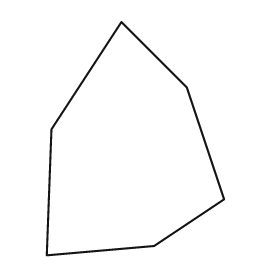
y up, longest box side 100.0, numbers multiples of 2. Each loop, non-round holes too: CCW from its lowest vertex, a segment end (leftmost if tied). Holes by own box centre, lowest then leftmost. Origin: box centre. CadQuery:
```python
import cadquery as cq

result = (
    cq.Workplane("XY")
    .moveTo(-38.0, -50.0)
    .lineTo(8.0, -46.0)
    .lineTo(38.0, -26.0)
    .lineTo(22.0, 22.0)
    .lineTo(-6.0, 50.0)
    .lineTo(-36.0, 4.0)
    .close()
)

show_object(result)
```